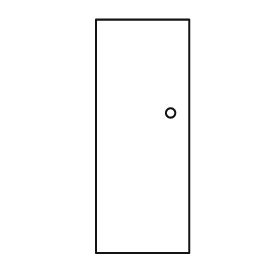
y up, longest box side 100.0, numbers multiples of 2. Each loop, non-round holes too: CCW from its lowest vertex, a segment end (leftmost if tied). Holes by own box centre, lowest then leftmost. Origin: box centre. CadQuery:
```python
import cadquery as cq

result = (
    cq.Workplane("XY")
    .moveTo(-20.0, -50.0)
    .lineTo(20.0, -50.0)
    .lineTo(20.0, 50.0)
    .lineTo(-20.0, 50.0)
    .close()
    .moveTo(12.0, 10.0)
    .circle(2.0)
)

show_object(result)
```